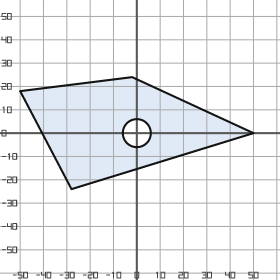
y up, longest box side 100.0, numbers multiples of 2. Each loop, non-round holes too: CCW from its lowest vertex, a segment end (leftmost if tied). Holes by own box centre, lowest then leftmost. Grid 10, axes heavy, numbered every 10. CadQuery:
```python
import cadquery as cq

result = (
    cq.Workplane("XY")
    .moveTo(-28.0, -24.0)
    .lineTo(50.0, 0.0)
    .lineTo(-2.0, 24.0)
    .lineTo(-50.0, 18.0)
    .close()
    .moveTo(0.0, 0.0)
    .circle(6.0)
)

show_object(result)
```